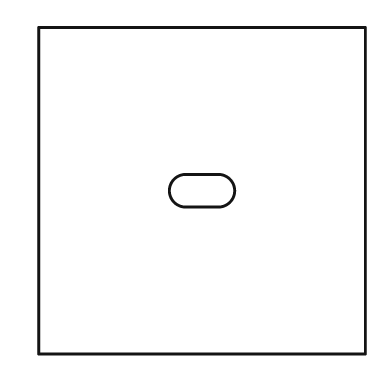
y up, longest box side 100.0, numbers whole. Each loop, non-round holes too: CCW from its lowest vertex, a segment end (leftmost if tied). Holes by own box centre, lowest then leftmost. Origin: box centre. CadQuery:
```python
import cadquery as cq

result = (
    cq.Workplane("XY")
    .moveTo(-50.0, -50.0)
    .lineTo(50.0, -50.0)
    .lineTo(50.0, 50.0)
    .lineTo(-50.0, 50.0)
    .close()
    .moveTo(-5.0, -5.0)
    .lineTo(5.0, -5.0)
    .threePointArc((10.0, 0.0), (5.0, 5.0))
    .lineTo(-5.0, 5.0)
    .threePointArc((-10.0, 0.0), (-5.0, -5.0))
    .close()
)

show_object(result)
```